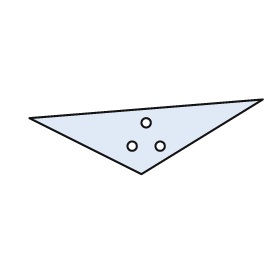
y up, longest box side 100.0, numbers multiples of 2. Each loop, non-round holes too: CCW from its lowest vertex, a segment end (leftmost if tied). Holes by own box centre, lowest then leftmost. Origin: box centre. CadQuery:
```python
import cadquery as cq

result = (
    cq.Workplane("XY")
    .moveTo(-2.0, -16.0)
    .lineTo(50.0, 16.0)
    .lineTo(-50.0, 8.0)
    .close()
    .moveTo(-6.0, -4.0)
    .circle(2.0)
    .moveTo(6.0, -4.0)
    .circle(2.0)
    .moveTo(0.0, 6.0)
    .circle(2.0)
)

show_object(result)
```